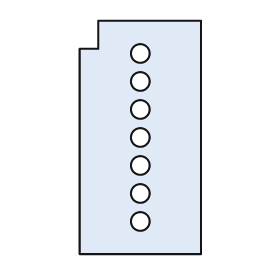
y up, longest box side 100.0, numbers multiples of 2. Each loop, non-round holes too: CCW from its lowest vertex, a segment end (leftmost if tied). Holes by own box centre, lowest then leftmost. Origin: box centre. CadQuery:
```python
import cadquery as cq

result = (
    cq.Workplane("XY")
    .moveTo(-26.0, -50.0)
    .lineTo(26.0, -50.0)
    .lineTo(26.0, 50.0)
    .lineTo(-18.0, 50.0)
    .lineTo(-18.0, 38.0)
    .lineTo(-26.0, 38.0)
    .close()
    .moveTo(0.0, -36.0)
    .circle(4.0)
    .moveTo(0.0, -24.0)
    .circle(4.0)
    .moveTo(0.0, -12.0)
    .circle(4.0)
    .moveTo(0.0, 0.0)
    .circle(4.0)
    .moveTo(0.0, 12.0)
    .circle(4.0)
    .moveTo(0.0, 24.0)
    .circle(4.0)
    .moveTo(0.0, 36.0)
    .circle(4.0)
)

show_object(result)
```